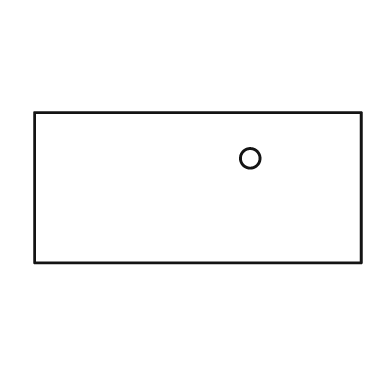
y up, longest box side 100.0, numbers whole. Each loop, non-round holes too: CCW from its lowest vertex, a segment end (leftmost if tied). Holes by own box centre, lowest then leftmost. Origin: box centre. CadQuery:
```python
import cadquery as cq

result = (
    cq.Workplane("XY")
    .moveTo(-50.0, -23.0)
    .lineTo(50.0, -23.0)
    .lineTo(50.0, 23.0)
    .lineTo(-50.0, 23.0)
    .close()
    .moveTo(16.0, 9.0)
    .circle(3.0)
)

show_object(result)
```